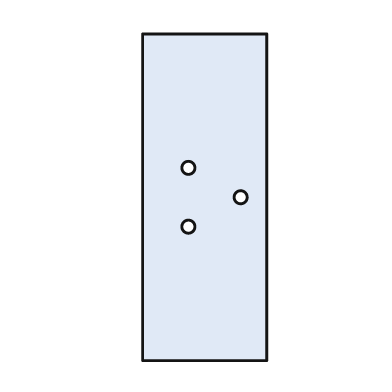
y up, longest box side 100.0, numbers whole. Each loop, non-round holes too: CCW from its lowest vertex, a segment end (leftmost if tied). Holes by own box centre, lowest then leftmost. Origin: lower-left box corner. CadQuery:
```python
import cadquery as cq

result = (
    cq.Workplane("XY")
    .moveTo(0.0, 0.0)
    .lineTo(38.0, 0.0)
    .lineTo(38.0, 100.0)
    .lineTo(0.0, 100.0)
    .close()
    .moveTo(14.0, 41.0)
    .circle(2.0)
    .moveTo(30.0, 50.0)
    .circle(2.0)
    .moveTo(14.0, 59.0)
    .circle(2.0)
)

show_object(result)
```